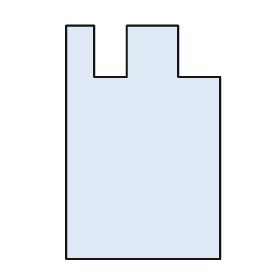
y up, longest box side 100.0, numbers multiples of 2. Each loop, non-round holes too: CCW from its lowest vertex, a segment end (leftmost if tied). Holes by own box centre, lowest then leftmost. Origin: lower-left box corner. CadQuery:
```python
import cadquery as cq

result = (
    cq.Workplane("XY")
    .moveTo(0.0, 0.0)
    .lineTo(66.0, 0.0)
    .lineTo(66.0, 78.0)
    .lineTo(48.0, 78.0)
    .lineTo(48.0, 100.0)
    .lineTo(26.0, 100.0)
    .lineTo(26.0, 78.0)
    .lineTo(12.0, 78.0)
    .lineTo(12.0, 100.0)
    .lineTo(0.0, 100.0)
    .close()
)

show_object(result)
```